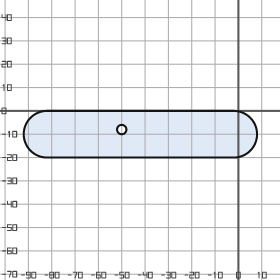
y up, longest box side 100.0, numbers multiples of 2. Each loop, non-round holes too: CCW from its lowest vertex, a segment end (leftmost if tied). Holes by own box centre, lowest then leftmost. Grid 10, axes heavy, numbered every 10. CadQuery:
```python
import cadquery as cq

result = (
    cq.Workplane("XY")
    .moveTo(-82.0, -20.0)
    .lineTo(-2.0, -20.0)
    .threePointArc((8.0, -10.0), (-2.0, 0.0))
    .lineTo(-82.0, 0.0)
    .threePointArc((-92.0, -10.0), (-82.0, -20.0))
    .close()
    .moveTo(-50.0, -8.0)
    .circle(2.0)
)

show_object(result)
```